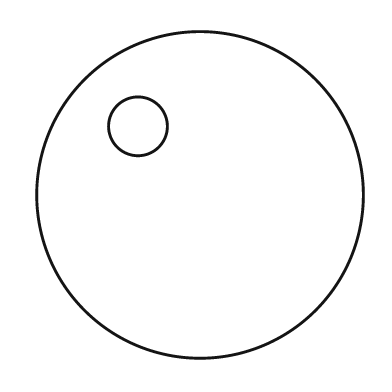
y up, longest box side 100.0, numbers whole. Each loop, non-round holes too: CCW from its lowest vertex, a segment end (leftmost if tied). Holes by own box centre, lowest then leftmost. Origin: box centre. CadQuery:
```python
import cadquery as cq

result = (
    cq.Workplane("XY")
    .moveTo(0.0, 0.0)
    .circle(50.0)
    .moveTo(-19.0, 21.0)
    .circle(9.0)
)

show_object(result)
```